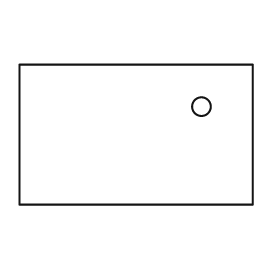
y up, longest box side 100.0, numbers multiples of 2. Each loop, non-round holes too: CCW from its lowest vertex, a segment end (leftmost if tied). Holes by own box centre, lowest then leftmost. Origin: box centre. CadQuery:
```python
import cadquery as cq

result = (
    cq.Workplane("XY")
    .moveTo(-50.0, -30.0)
    .lineTo(50.0, -30.0)
    .lineTo(50.0, 30.0)
    .lineTo(-50.0, 30.0)
    .close()
    .moveTo(28.0, 12.0)
    .circle(4.0)
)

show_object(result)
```